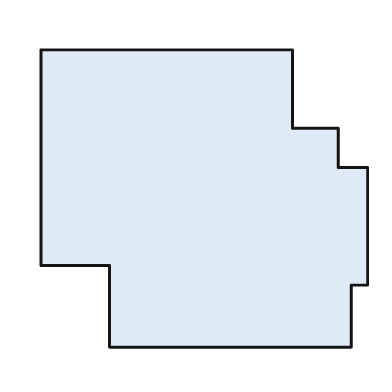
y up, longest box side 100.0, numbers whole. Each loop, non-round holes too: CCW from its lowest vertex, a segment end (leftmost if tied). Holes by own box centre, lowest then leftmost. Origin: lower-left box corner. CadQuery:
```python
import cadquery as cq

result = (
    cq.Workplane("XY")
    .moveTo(21.0, 0.0)
    .lineTo(95.0, 0.0)
    .lineTo(95.0, 19.0)
    .lineTo(100.0, 19.0)
    .lineTo(100.0, 55.0)
    .lineTo(91.0, 55.0)
    .lineTo(91.0, 67.0)
    .lineTo(77.0, 67.0)
    .lineTo(77.0, 91.0)
    .lineTo(0.0, 91.0)
    .lineTo(0.0, 25.0)
    .lineTo(21.0, 25.0)
    .close()
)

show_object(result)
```